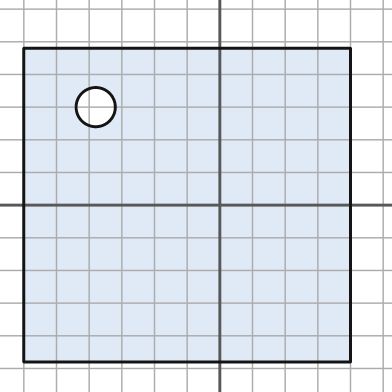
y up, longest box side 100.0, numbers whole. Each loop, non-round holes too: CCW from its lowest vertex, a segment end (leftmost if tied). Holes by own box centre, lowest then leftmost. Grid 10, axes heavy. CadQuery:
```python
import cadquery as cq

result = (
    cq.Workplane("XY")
    .moveTo(-60.0, -48.0)
    .lineTo(40.0, -48.0)
    .lineTo(40.0, 48.0)
    .lineTo(-60.0, 48.0)
    .close()
    .moveTo(-38.0, 30.0)
    .circle(6.0)
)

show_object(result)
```